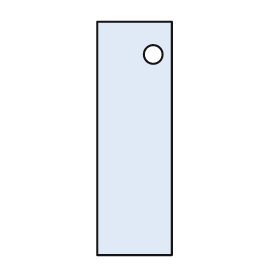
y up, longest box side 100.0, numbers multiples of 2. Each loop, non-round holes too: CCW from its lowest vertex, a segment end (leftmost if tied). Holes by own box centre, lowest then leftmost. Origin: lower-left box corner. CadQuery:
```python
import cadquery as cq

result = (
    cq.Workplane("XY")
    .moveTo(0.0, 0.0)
    .lineTo(32.0, 0.0)
    .lineTo(32.0, 100.0)
    .lineTo(0.0, 100.0)
    .close()
    .moveTo(24.0, 86.0)
    .circle(4.0)
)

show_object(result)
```